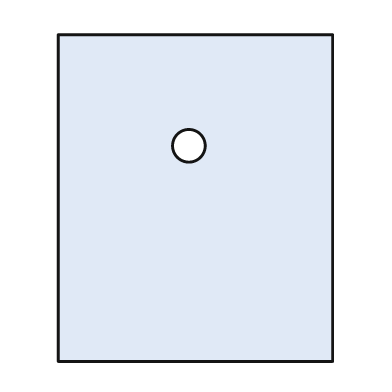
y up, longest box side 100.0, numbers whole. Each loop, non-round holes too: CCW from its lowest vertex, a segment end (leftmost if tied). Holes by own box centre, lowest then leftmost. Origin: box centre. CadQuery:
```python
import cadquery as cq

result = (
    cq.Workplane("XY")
    .moveTo(-42.0, -50.0)
    .lineTo(42.0, -50.0)
    .lineTo(42.0, 50.0)
    .lineTo(-42.0, 50.0)
    .close()
    .moveTo(-2.0, 16.0)
    .circle(5.0)
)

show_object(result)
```